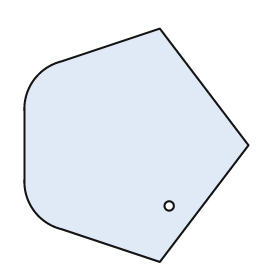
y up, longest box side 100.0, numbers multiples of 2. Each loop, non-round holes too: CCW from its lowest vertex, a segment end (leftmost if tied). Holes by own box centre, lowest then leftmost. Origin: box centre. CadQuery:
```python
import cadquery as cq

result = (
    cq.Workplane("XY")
    .moveTo(10.0, -50.0)
    .lineTo(48.0, 0.0)
    .lineTo(10.0, 50.0)
    .lineTo(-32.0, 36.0)
    .threePointArc((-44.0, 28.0), (-48.0, 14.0))
    .lineTo(-48.0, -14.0)
    .threePointArc((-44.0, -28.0), (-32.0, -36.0))
    .close()
    .moveTo(14.0, -26.0)
    .circle(2.0)
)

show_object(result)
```